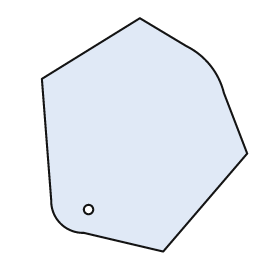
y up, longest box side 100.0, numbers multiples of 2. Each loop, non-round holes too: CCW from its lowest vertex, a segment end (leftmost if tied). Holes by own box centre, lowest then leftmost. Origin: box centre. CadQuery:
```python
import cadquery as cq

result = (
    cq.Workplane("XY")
    .moveTo(8.0, -50.0)
    .lineTo(44.0, -8.0)
    .lineTo(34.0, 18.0)
    .threePointArc((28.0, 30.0), (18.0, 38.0))
    .lineTo(-2.0, 50.0)
    .lineTo(-44.0, 24.0)
    .lineTo(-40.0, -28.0)
    .threePointArc((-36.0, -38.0), (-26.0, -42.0))
    .close()
    .moveTo(-24.0, -32.0)
    .circle(2.0)
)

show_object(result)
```